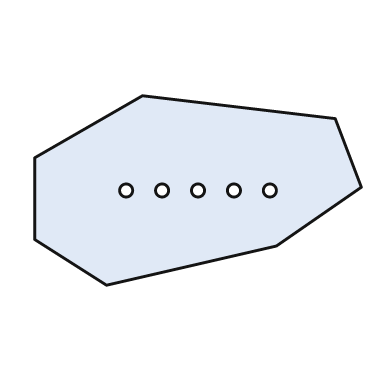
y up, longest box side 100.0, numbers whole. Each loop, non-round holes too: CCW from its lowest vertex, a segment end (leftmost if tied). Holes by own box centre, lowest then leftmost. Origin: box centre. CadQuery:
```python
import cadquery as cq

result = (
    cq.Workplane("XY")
    .moveTo(-28.0, -29.0)
    .lineTo(24.0, -17.0)
    .lineTo(50.0, 1.0)
    .lineTo(42.0, 22.0)
    .lineTo(-17.0, 29.0)
    .lineTo(-50.0, 10.0)
    .lineTo(-50.0, -15.0)
    .close()
    .moveTo(-22.0, 0.0)
    .circle(2.0)
    .moveTo(-11.0, 0.0)
    .circle(2.0)
    .moveTo(0.0, 0.0)
    .circle(2.0)
    .moveTo(11.0, 0.0)
    .circle(2.0)
    .moveTo(22.0, 0.0)
    .circle(2.0)
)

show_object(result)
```